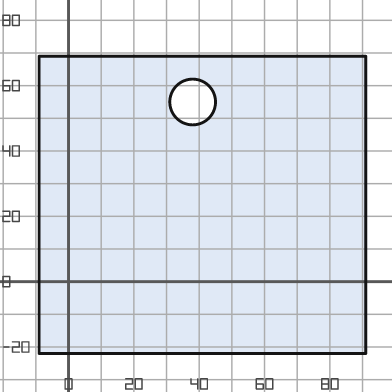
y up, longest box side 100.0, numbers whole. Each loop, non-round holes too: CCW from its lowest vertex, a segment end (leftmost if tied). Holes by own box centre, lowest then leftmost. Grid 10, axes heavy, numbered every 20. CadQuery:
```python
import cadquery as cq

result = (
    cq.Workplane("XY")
    .moveTo(-9.0, -22.0)
    .lineTo(91.0, -22.0)
    .lineTo(91.0, 69.0)
    .lineTo(-9.0, 69.0)
    .close()
    .moveTo(38.0, 55.0)
    .circle(7.0)
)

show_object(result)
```